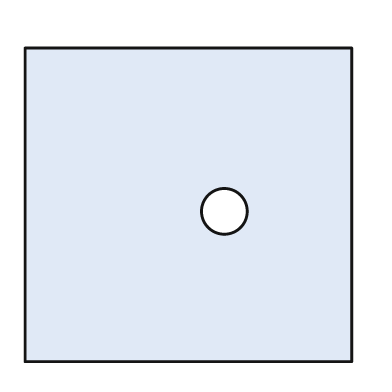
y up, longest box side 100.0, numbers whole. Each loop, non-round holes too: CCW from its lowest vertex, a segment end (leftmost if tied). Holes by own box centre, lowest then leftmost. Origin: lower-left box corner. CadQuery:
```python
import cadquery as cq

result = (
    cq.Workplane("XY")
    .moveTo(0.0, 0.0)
    .lineTo(100.0, 0.0)
    .lineTo(100.0, 96.0)
    .lineTo(0.0, 96.0)
    .close()
    .moveTo(61.0, 46.0)
    .circle(7.0)
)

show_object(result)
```